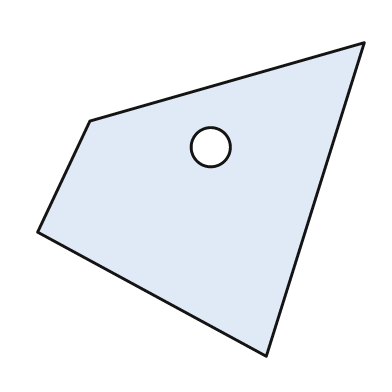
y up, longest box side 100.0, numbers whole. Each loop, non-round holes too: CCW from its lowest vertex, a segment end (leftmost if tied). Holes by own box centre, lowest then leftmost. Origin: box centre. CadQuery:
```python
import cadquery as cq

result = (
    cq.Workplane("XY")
    .moveTo(20.0, -48.0)
    .lineTo(50.0, 48.0)
    .lineTo(-34.0, 24.0)
    .lineTo(-50.0, -10.0)
    .close()
    .moveTo(3.0, 16.0)
    .circle(6.0)
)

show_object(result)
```